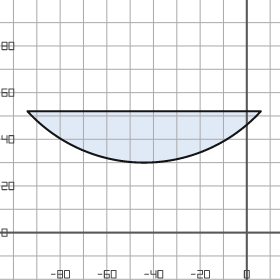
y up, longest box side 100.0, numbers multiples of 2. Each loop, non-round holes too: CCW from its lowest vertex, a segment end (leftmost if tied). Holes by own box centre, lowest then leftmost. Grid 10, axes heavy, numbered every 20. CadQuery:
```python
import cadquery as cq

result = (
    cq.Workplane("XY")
    .moveTo(-94.0, 52.0)
    .threePointArc((-44.0, 30.0), (6.0, 52.0))
    .close()
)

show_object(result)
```